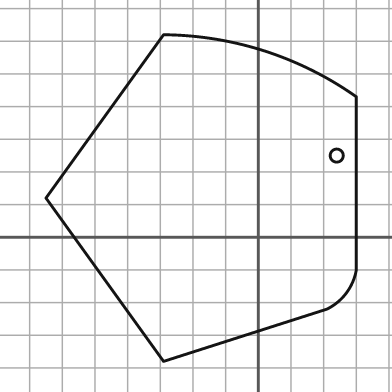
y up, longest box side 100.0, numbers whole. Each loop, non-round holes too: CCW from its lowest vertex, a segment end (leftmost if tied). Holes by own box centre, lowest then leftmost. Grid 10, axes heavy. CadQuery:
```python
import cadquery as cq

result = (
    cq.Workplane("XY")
    .moveTo(-29.0, -38.0)
    .lineTo(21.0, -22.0)
    .threePointArc((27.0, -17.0), (30.0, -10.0))
    .lineTo(30.0, 43.0)
    .threePointArc((2.0, 57.0), (-29.0, 62.0))
    .lineTo(-65.0, 12.0)
    .close()
    .moveTo(24.0, 25.0)
    .circle(2.0)
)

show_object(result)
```